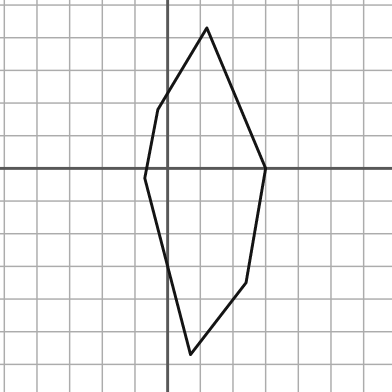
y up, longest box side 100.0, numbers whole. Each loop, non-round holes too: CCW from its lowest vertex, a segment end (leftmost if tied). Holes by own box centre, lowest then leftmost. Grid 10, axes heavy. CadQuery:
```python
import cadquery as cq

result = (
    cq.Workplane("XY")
    .moveTo(7.0, -57.0)
    .lineTo(24.0, -35.0)
    .lineTo(30.0, 0.0)
    .lineTo(12.0, 43.0)
    .lineTo(-3.0, 18.0)
    .lineTo(-7.0, -3.0)
    .close()
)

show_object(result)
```